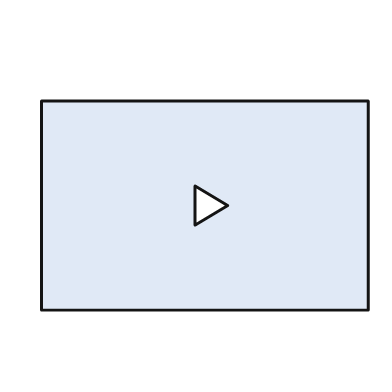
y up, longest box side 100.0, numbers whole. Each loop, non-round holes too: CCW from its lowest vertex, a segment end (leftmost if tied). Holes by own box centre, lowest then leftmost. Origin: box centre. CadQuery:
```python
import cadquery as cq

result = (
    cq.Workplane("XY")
    .moveTo(-50.0, -32.0)
    .lineTo(50.0, -32.0)
    .lineTo(50.0, 32.0)
    .lineTo(-50.0, 32.0)
    .close()
    .moveTo(-3.0, -6.0)
    .lineTo(7.0, 0.0)
    .lineTo(-3.0, 6.0)
    .close()
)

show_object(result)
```